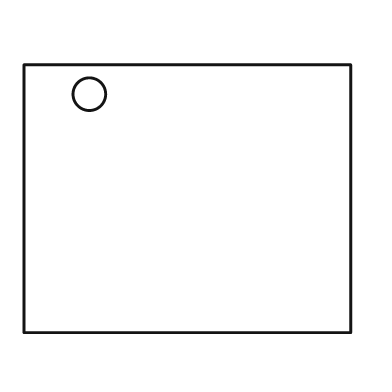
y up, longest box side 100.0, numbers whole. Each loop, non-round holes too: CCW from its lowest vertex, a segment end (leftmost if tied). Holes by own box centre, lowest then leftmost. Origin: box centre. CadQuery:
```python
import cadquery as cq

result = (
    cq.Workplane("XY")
    .moveTo(-50.0, -41.0)
    .lineTo(50.0, -41.0)
    .lineTo(50.0, 41.0)
    .lineTo(-50.0, 41.0)
    .close()
    .moveTo(-30.0, 32.0)
    .circle(5.0)
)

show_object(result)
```